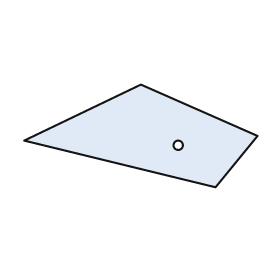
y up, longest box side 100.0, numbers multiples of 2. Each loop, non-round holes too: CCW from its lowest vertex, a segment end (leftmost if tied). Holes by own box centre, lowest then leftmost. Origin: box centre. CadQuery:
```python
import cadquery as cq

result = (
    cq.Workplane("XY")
    .moveTo(32.0, -22.0)
    .lineTo(50.0, 0.0)
    .lineTo(0.0, 22.0)
    .lineTo(-50.0, -2.0)
    .close()
    .moveTo(16.0, -4.0)
    .circle(2.0)
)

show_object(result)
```